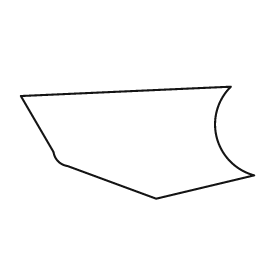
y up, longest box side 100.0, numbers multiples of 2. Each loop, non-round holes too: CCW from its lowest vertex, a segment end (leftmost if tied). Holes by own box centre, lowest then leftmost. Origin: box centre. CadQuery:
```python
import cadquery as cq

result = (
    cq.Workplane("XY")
    .moveTo(8.0, -24.0)
    .lineTo(50.0, -14.0)
    .threePointArc((34.0, 2.0), (40.0, 24.0))
    .lineTo(-50.0, 20.0)
    .lineTo(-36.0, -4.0)
    .threePointArc((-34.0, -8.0), (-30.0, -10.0))
    .close()
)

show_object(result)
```